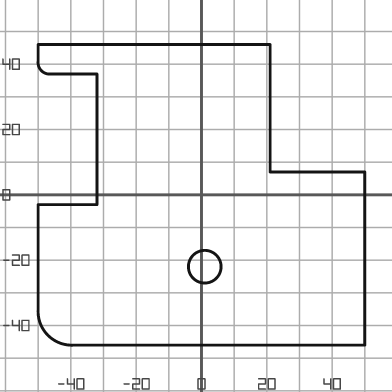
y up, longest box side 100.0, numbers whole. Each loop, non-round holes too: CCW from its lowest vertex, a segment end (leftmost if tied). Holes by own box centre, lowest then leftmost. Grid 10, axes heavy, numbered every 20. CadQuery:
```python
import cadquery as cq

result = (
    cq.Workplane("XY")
    .moveTo(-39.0, -46.0)
    .lineTo(50.0, -46.0)
    .lineTo(50.0, 7.0)
    .lineTo(21.0, 7.0)
    .lineTo(21.0, 46.0)
    .lineTo(-50.0, 46.0)
    .lineTo(-50.0, 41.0)
    .threePointArc((-49.0, 38.0), (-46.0, 37.0))
    .lineTo(-32.0, 37.0)
    .lineTo(-32.0, -3.0)
    .lineTo(-50.0, -3.0)
    .lineTo(-50.0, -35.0)
    .threePointArc((-47.0, -43.0), (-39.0, -46.0))
    .close()
    .moveTo(1.0, -22.0)
    .circle(5.0)
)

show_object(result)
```